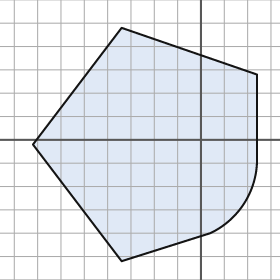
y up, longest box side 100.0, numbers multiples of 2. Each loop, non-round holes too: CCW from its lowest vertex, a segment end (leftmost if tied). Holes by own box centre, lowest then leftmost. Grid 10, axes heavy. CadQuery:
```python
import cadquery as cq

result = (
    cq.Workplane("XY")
    .moveTo(-34.0, -52.0)
    .lineTo(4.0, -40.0)
    .threePointArc((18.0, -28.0), (24.0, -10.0))
    .lineTo(24.0, 28.0)
    .lineTo(-34.0, 48.0)
    .lineTo(-72.0, -2.0)
    .close()
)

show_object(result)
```